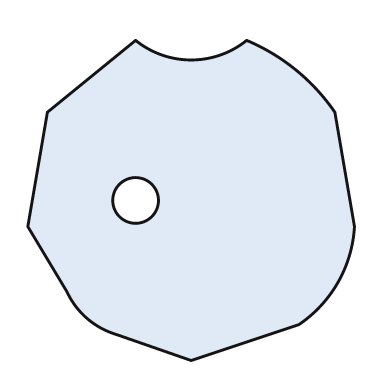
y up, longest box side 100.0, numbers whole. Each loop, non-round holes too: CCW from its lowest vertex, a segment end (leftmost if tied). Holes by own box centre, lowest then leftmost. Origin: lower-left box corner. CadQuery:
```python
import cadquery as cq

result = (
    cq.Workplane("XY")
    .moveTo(50.0, 0.0)
    .lineTo(83.0, 11.0)
    .threePointArc((95.0, 24.0), (100.0, 41.0))
    .lineTo(94.0, 76.0)
    .threePointArc((82.0, 89.0), (67.0, 98.0))
    .threePointArc((50.0, 92.0), (33.0, 98.0))
    .lineTo(6.0, 76.0)
    .lineTo(0.0, 41.0)
    .lineTo(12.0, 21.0)
    .threePointArc((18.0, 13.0), (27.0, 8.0))
    .close()
    .moveTo(33.0, 49.0)
    .circle(7.0)
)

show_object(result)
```